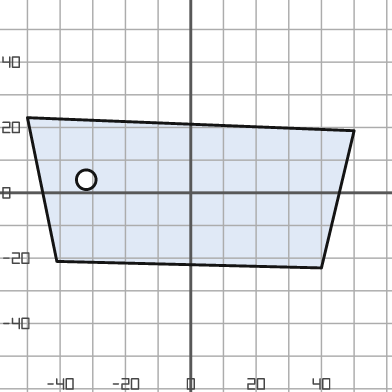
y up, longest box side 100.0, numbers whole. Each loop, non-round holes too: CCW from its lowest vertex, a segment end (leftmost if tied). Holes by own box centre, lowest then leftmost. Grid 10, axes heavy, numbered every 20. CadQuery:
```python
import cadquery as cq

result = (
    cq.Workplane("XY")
    .moveTo(40.0, -23.0)
    .lineTo(50.0, 19.0)
    .lineTo(-50.0, 23.0)
    .lineTo(-41.0, -21.0)
    .close()
    .moveTo(-32.0, 4.0)
    .circle(3.0)
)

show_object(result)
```